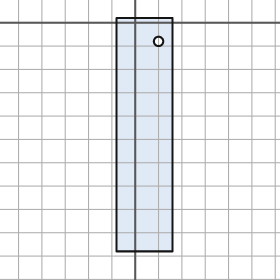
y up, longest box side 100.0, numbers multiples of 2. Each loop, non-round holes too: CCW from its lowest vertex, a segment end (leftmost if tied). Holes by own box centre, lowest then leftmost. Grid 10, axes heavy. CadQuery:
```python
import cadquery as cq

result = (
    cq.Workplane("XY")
    .moveTo(-8.0, -98.0)
    .lineTo(16.0, -98.0)
    .lineTo(16.0, 2.0)
    .lineTo(-8.0, 2.0)
    .close()
    .moveTo(10.0, -8.0)
    .circle(2.0)
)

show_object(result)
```